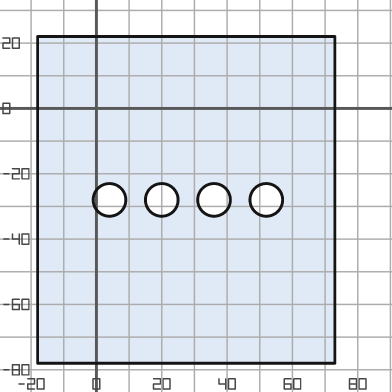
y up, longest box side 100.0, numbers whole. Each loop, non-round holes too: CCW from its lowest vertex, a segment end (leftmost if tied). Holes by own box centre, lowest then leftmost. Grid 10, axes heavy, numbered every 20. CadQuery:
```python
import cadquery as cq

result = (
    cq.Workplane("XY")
    .moveTo(-18.0, -78.0)
    .lineTo(73.0, -78.0)
    .lineTo(73.0, 22.0)
    .lineTo(-18.0, 22.0)
    .close()
    .moveTo(4.0, -28.0)
    .circle(5.0)
    .moveTo(20.0, -28.0)
    .circle(5.0)
    .moveTo(36.0, -28.0)
    .circle(5.0)
    .moveTo(52.0, -28.0)
    .circle(5.0)
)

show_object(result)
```